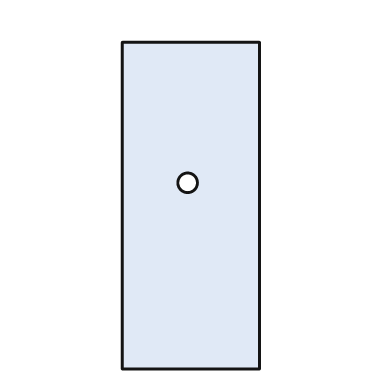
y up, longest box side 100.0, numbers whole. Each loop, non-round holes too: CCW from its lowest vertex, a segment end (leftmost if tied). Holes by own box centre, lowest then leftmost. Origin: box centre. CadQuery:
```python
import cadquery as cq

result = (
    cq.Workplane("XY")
    .moveTo(-21.0, -50.0)
    .lineTo(21.0, -50.0)
    .lineTo(21.0, 50.0)
    .lineTo(-21.0, 50.0)
    .close()
    .moveTo(-1.0, 7.0)
    .circle(3.0)
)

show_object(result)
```